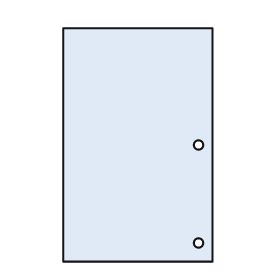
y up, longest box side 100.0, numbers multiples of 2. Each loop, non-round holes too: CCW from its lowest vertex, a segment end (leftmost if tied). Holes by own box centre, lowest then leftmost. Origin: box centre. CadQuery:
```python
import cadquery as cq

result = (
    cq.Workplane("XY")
    .moveTo(-32.0, -50.0)
    .lineTo(32.0, -50.0)
    .lineTo(32.0, 50.0)
    .lineTo(-32.0, 50.0)
    .close()
    .moveTo(26.0, -42.0)
    .circle(2.0)
    .moveTo(26.0, 0.0)
    .circle(2.0)
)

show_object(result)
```